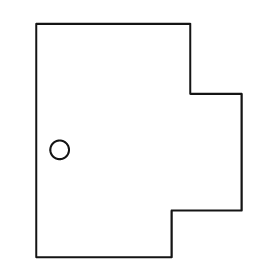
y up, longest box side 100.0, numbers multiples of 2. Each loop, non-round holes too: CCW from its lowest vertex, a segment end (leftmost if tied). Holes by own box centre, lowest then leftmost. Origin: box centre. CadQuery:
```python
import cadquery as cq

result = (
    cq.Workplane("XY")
    .moveTo(-44.0, -50.0)
    .lineTo(14.0, -50.0)
    .lineTo(14.0, -30.0)
    .lineTo(44.0, -30.0)
    .lineTo(44.0, 20.0)
    .lineTo(22.0, 20.0)
    .lineTo(22.0, 50.0)
    .lineTo(-44.0, 50.0)
    .close()
    .moveTo(-34.0, -4.0)
    .circle(4.0)
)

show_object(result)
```